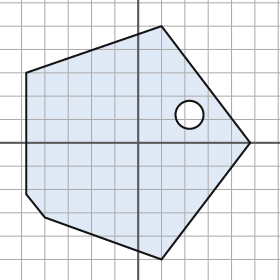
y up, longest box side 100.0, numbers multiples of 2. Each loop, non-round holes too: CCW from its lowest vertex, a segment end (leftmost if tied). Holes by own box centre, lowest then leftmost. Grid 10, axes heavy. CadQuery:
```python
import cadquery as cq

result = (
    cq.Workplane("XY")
    .moveTo(10.0, -50.0)
    .lineTo(48.0, 0.0)
    .lineTo(10.0, 50.0)
    .lineTo(-48.0, 30.0)
    .lineTo(-48.0, -22.0)
    .lineTo(-40.0, -32.0)
    .close()
    .moveTo(22.0, 12.0)
    .circle(6.0)
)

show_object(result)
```